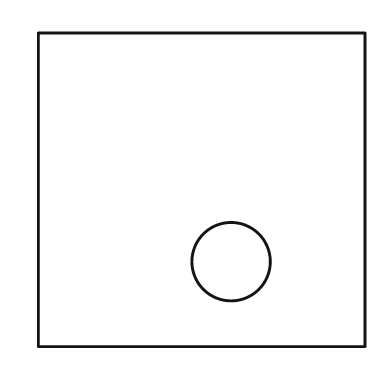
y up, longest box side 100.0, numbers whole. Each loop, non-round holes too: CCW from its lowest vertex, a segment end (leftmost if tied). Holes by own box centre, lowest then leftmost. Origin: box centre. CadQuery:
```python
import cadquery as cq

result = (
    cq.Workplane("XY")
    .moveTo(-50.0, -48.0)
    .lineTo(50.0, -48.0)
    .lineTo(50.0, 48.0)
    .lineTo(-50.0, 48.0)
    .close()
    .moveTo(9.0, -22.0)
    .circle(12.0)
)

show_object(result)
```